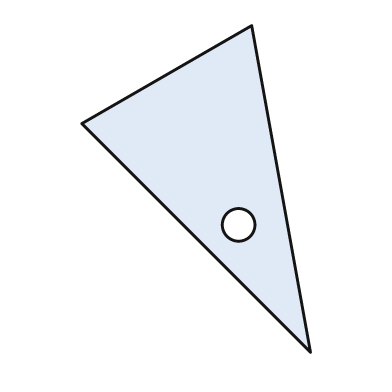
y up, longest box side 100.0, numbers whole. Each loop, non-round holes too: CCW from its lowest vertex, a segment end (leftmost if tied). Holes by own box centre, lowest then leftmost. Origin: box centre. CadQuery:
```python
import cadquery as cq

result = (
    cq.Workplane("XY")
    .moveTo(35.0, -50.0)
    .lineTo(17.0, 50.0)
    .lineTo(-35.0, 20.0)
    .close()
    .moveTo(13.0, -11.0)
    .circle(5.0)
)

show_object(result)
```